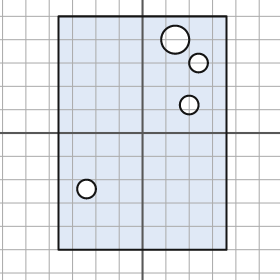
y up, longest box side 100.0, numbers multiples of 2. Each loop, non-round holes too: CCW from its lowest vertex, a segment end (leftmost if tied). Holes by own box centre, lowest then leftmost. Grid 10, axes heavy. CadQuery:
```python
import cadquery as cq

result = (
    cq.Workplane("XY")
    .moveTo(-36.0, -50.0)
    .lineTo(36.0, -50.0)
    .lineTo(36.0, 50.0)
    .lineTo(-36.0, 50.0)
    .close()
    .moveTo(-24.0, -24.0)
    .circle(4.0)
    .moveTo(20.0, 12.0)
    .circle(4.0)
    .moveTo(24.0, 30.0)
    .circle(4.0)
    .moveTo(14.0, 40.0)
    .circle(6.0)
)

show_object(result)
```